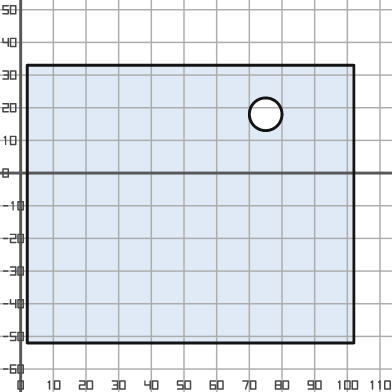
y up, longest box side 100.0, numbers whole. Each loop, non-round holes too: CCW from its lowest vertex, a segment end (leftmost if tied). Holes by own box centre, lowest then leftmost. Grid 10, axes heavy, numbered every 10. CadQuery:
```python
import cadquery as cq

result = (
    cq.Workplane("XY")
    .moveTo(2.0, -52.0)
    .lineTo(102.0, -52.0)
    .lineTo(102.0, 33.0)
    .lineTo(2.0, 33.0)
    .close()
    .moveTo(75.0, 18.0)
    .circle(5.0)
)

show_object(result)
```